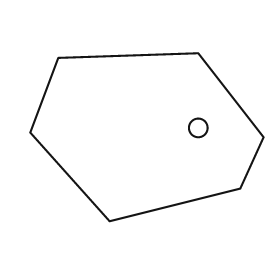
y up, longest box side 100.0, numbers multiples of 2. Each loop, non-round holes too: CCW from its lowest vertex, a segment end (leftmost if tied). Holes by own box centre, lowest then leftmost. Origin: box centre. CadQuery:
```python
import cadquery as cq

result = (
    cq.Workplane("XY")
    .moveTo(-16.0, -36.0)
    .lineTo(40.0, -22.0)
    .lineTo(50.0, 0.0)
    .lineTo(22.0, 36.0)
    .lineTo(-38.0, 34.0)
    .lineTo(-50.0, 2.0)
    .close()
    .moveTo(22.0, 4.0)
    .circle(4.0)
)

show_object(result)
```